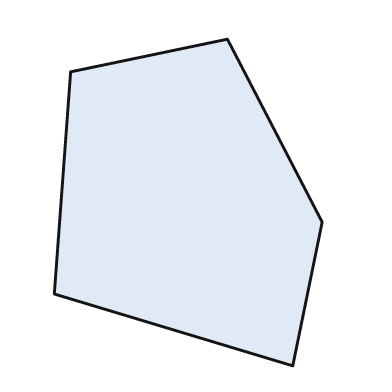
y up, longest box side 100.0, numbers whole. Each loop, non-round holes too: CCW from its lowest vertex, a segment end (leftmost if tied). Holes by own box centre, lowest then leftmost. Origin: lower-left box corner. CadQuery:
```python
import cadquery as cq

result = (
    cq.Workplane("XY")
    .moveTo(73.0, 0.0)
    .lineTo(82.0, 44.0)
    .lineTo(53.0, 100.0)
    .lineTo(5.0, 90.0)
    .lineTo(0.0, 22.0)
    .close()
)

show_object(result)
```